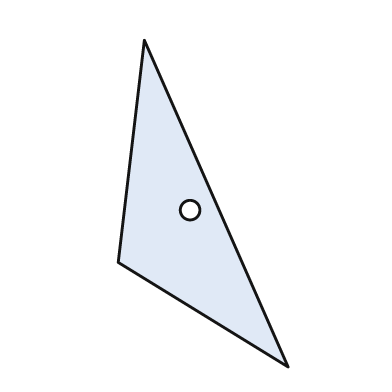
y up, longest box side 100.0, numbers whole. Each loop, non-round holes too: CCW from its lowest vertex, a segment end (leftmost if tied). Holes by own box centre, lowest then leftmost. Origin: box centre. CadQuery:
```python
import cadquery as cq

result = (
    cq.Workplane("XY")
    .moveTo(26.0, -50.0)
    .lineTo(-18.0, 50.0)
    .lineTo(-26.0, -18.0)
    .close()
    .moveTo(-4.0, -2.0)
    .circle(3.0)
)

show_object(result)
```